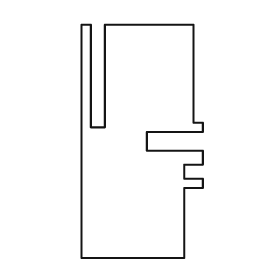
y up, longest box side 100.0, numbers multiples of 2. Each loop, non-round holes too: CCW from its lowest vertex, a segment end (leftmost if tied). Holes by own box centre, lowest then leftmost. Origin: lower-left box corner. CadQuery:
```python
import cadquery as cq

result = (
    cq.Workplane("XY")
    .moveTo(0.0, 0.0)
    .lineTo(44.0, 0.0)
    .lineTo(44.0, 30.0)
    .lineTo(52.0, 30.0)
    .lineTo(52.0, 34.0)
    .lineTo(44.0, 34.0)
    .lineTo(44.0, 40.0)
    .lineTo(52.0, 40.0)
    .lineTo(52.0, 46.0)
    .lineTo(28.0, 46.0)
    .lineTo(28.0, 54.0)
    .lineTo(52.0, 54.0)
    .lineTo(52.0, 58.0)
    .lineTo(48.0, 58.0)
    .lineTo(48.0, 100.0)
    .lineTo(10.0, 100.0)
    .lineTo(10.0, 56.0)
    .lineTo(4.0, 56.0)
    .lineTo(4.0, 100.0)
    .lineTo(0.0, 100.0)
    .close()
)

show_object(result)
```